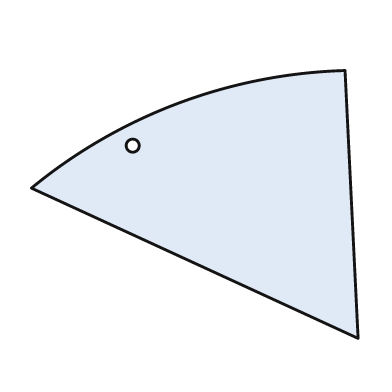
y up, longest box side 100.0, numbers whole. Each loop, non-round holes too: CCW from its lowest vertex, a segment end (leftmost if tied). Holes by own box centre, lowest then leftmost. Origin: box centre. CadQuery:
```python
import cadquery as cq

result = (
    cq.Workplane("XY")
    .moveTo(50.0, -41.0)
    .lineTo(46.0, 41.0)
    .threePointArc((-5.0, 31.0), (-50.0, 5.0))
    .close()
    .moveTo(-19.0, 18.0)
    .circle(2.0)
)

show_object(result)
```